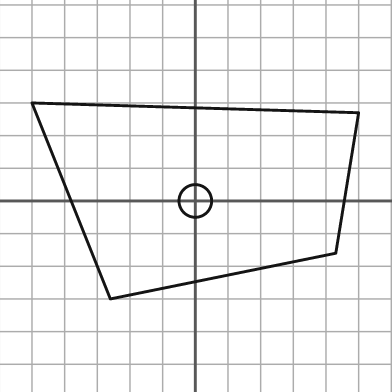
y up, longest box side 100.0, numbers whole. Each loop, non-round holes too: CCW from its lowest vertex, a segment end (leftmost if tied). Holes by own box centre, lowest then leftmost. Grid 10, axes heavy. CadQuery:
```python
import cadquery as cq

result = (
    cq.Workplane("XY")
    .moveTo(-26.0, -30.0)
    .lineTo(43.0, -16.0)
    .lineTo(50.0, 27.0)
    .lineTo(-50.0, 30.0)
    .close()
    .moveTo(0.0, 0.0)
    .circle(5.0)
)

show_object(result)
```